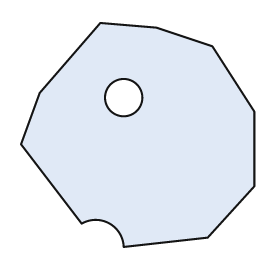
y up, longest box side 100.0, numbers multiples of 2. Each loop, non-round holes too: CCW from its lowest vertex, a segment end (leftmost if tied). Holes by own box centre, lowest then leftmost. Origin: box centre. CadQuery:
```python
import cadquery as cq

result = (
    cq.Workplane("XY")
    .moveTo(-6.0, -48.0)
    .lineTo(30.0, -44.0)
    .lineTo(50.0, -22.0)
    .lineTo(50.0, 10.0)
    .lineTo(32.0, 38.0)
    .lineTo(8.0, 46.0)
    .lineTo(-16.0, 48.0)
    .lineTo(-42.0, 18.0)
    .lineTo(-50.0, -4.0)
    .lineTo(-24.0, -38.0)
    .threePointArc((-12.0, -38.0), (-6.0, -48.0))
    .close()
    .moveTo(-6.0, 16.0)
    .circle(8.0)
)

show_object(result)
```